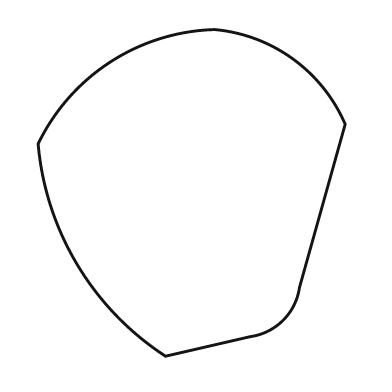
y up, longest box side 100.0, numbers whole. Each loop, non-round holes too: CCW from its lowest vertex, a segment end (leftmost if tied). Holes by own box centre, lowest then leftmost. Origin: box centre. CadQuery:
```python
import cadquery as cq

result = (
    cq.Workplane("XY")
    .moveTo(-8.0, -50.0)
    .lineTo(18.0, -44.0)
    .threePointArc((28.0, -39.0), (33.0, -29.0))
    .lineTo(47.0, 21.0)
    .threePointArc((31.0, 41.0), (7.0, 50.0))
    .threePointArc((-25.0, 40.0), (-47.0, 15.0))
    .threePointArc((-35.0, -22.0), (-8.0, -50.0))
    .close()
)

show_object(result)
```